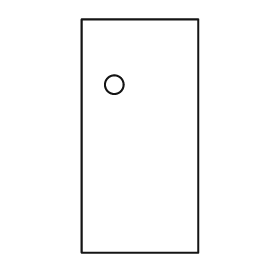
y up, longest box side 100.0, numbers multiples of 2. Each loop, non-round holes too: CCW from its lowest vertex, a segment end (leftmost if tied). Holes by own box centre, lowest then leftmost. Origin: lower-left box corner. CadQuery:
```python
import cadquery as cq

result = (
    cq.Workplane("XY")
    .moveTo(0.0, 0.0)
    .lineTo(50.0, 0.0)
    .lineTo(50.0, 100.0)
    .lineTo(0.0, 100.0)
    .close()
    .moveTo(14.0, 72.0)
    .circle(4.0)
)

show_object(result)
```